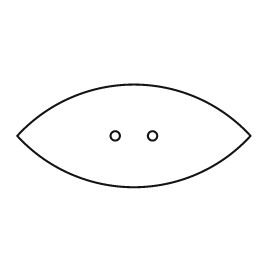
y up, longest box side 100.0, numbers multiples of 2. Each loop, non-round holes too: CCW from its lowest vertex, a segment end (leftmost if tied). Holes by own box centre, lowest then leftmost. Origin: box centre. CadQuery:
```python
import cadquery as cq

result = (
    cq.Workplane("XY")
    .moveTo(-50.0, 0.0)
    .threePointArc((0.0, -22.0), (50.0, 0.0))
    .threePointArc((0.0, 22.0), (-50.0, 0.0))
    .close()
    .moveTo(-8.0, 0.0)
    .circle(2.0)
    .moveTo(8.0, 0.0)
    .circle(2.0)
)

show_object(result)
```